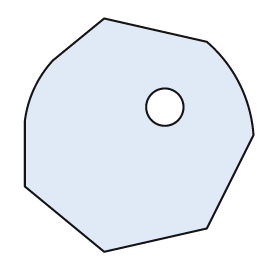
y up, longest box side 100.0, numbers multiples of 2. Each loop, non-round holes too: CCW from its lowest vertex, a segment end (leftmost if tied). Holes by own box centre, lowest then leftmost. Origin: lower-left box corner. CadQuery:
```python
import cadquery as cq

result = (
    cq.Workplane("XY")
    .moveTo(34.0, 0.0)
    .lineTo(78.0, 10.0)
    .lineTo(98.0, 50.0)
    .threePointArc((92.0, 72.0), (78.0, 90.0))
    .lineTo(34.0, 100.0)
    .lineTo(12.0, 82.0)
    .threePointArc((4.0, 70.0), (0.0, 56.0))
    .lineTo(0.0, 28.0)
    .close()
    .moveTo(60.0, 62.0)
    .circle(8.0)
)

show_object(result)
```